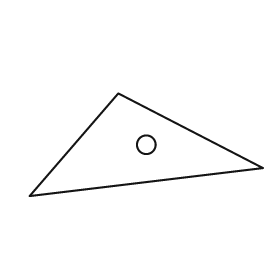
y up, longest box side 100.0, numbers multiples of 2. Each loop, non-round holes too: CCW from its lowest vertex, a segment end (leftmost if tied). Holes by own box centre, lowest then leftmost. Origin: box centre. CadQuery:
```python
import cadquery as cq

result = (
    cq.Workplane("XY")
    .moveTo(-50.0, -22.0)
    .lineTo(50.0, -10.0)
    .lineTo(-12.0, 22.0)
    .close()
    .moveTo(0.0, 0.0)
    .circle(4.0)
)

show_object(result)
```